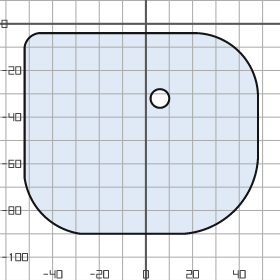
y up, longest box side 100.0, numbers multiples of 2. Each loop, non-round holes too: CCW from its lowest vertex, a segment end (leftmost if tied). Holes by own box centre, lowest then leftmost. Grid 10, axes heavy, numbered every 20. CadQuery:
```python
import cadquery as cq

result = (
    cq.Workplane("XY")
    .moveTo(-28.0, -90.0)
    .lineTo(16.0, -90.0)
    .threePointArc((38.0, -80.0), (48.0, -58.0))
    .lineTo(48.0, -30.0)
    .threePointArc((40.0, -12.0), (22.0, -4.0))
    .lineTo(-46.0, -4.0)
    .threePointArc((-50.0, -6.0), (-52.0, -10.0))
    .lineTo(-52.0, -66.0)
    .threePointArc((-44.0, -82.0), (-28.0, -90.0))
    .close()
    .moveTo(6.0, -32.0)
    .circle(4.0)
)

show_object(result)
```